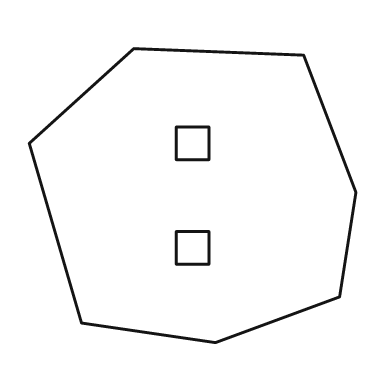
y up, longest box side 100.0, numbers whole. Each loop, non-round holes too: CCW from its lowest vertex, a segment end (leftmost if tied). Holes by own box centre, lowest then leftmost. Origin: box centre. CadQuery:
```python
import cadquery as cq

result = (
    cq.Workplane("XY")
    .moveTo(7.0, -45.0)
    .lineTo(45.0, -31.0)
    .lineTo(50.0, 1.0)
    .lineTo(34.0, 43.0)
    .lineTo(-18.0, 45.0)
    .lineTo(-50.0, 16.0)
    .lineTo(-34.0, -39.0)
    .close()
    .moveTo(-5.0, -21.0)
    .lineTo(5.0, -21.0)
    .lineTo(5.0, -11.0)
    .lineTo(-5.0, -11.0)
    .close()
    .moveTo(-5.0, 11.0)
    .lineTo(5.0, 11.0)
    .lineTo(5.0, 21.0)
    .lineTo(-5.0, 21.0)
    .close()
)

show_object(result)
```